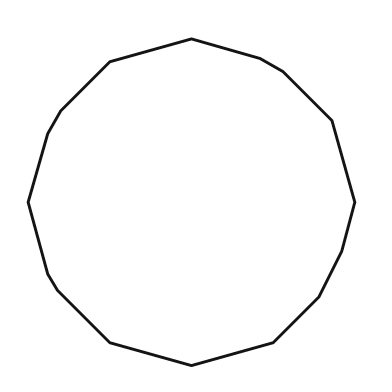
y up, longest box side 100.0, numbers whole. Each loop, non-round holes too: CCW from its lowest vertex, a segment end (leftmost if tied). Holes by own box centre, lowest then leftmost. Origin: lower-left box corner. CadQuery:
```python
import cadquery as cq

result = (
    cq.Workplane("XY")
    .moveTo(50.0, 0.0)
    .lineTo(75.0, 7.0)
    .lineTo(89.0, 21.0)
    .lineTo(96.0, 35.0)
    .lineTo(100.0, 50.0)
    .lineTo(93.0, 75.0)
    .lineTo(78.0, 90.0)
    .lineTo(71.0, 94.0)
    .lineTo(50.0, 100.0)
    .lineTo(25.0, 93.0)
    .lineTo(10.0, 78.0)
    .lineTo(6.0, 71.0)
    .lineTo(0.0, 50.0)
    .lineTo(6.0, 28.0)
    .lineTo(9.0, 23.0)
    .lineTo(25.0, 7.0)
    .close()
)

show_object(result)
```